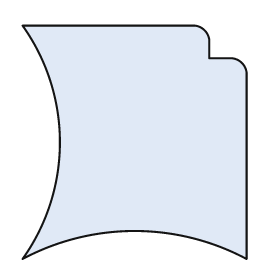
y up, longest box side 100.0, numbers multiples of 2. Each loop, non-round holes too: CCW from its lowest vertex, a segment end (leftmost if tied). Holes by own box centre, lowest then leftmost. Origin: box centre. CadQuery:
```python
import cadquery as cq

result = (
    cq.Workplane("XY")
    .moveTo(-48.0, -50.0)
    .threePointArc((0.0, -38.0), (48.0, -50.0))
    .lineTo(48.0, 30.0)
    .threePointArc((46.0, 34.0), (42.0, 36.0))
    .lineTo(32.0, 36.0)
    .lineTo(32.0, 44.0)
    .threePointArc((30.0, 48.0), (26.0, 50.0))
    .lineTo(-48.0, 50.0)
    .threePointArc((-32.0, 0.0), (-48.0, -50.0))
    .close()
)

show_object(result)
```